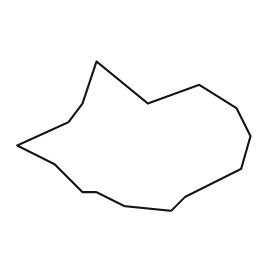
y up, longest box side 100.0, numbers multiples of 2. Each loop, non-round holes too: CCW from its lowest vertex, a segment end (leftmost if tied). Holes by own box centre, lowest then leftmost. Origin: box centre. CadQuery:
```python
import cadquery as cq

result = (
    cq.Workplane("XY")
    .moveTo(16.0, -32.0)
    .lineTo(22.0, -26.0)
    .lineTo(46.0, -14.0)
    .lineTo(50.0, 0.0)
    .lineTo(44.0, 12.0)
    .lineTo(28.0, 22.0)
    .lineTo(6.0, 14.0)
    .lineTo(-16.0, 32.0)
    .lineTo(-22.0, 14.0)
    .lineTo(-28.0, 6.0)
    .lineTo(-50.0, -4.0)
    .lineTo(-34.0, -12.0)
    .lineTo(-22.0, -24.0)
    .lineTo(-16.0, -24.0)
    .lineTo(-4.0, -30.0)
    .close()
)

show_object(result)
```